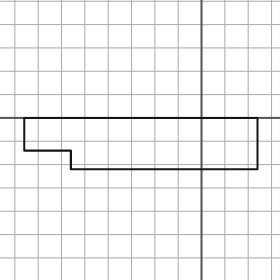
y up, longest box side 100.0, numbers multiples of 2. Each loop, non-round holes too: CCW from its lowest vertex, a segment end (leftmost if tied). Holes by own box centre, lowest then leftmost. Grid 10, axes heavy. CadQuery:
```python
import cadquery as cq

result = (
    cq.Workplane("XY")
    .moveTo(-56.0, -22.0)
    .lineTo(24.0, -22.0)
    .lineTo(24.0, 0.0)
    .lineTo(-76.0, 0.0)
    .lineTo(-76.0, -14.0)
    .lineTo(-56.0, -14.0)
    .close()
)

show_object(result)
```